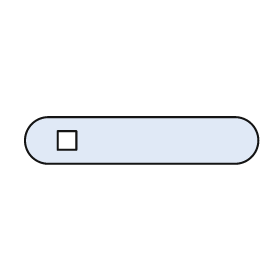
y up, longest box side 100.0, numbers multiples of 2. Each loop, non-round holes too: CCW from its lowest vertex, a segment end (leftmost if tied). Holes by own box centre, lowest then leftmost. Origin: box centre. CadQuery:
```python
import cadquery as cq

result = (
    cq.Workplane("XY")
    .moveTo(-40.0, -10.0)
    .lineTo(40.0, -10.0)
    .threePointArc((50.0, 0.0), (40.0, 10.0))
    .lineTo(-40.0, 10.0)
    .threePointArc((-50.0, 0.0), (-40.0, -10.0))
    .close()
    .moveTo(-36.0, -4.0)
    .lineTo(-28.0, -4.0)
    .lineTo(-28.0, 4.0)
    .lineTo(-36.0, 4.0)
    .close()
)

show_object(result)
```